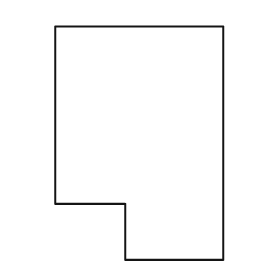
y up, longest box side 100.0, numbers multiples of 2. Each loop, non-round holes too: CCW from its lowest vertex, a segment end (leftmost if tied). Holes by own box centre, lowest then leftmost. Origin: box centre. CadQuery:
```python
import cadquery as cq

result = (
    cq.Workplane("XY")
    .moveTo(-6.0, -50.0)
    .lineTo(36.0, -50.0)
    .lineTo(36.0, 50.0)
    .lineTo(-36.0, 50.0)
    .lineTo(-36.0, -26.0)
    .lineTo(-6.0, -26.0)
    .close()
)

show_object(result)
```